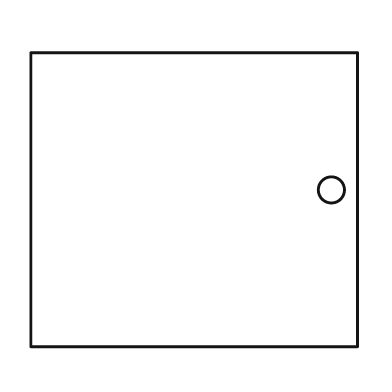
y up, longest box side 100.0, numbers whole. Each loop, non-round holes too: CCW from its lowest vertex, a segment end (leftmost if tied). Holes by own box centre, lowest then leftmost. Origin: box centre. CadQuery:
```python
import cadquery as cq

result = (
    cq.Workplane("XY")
    .moveTo(-50.0, -45.0)
    .lineTo(50.0, -45.0)
    .lineTo(50.0, 45.0)
    .lineTo(-50.0, 45.0)
    .close()
    .moveTo(42.0, 3.0)
    .circle(4.0)
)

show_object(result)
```